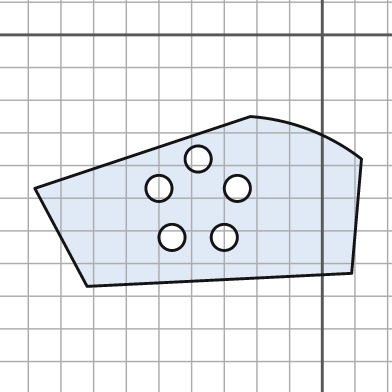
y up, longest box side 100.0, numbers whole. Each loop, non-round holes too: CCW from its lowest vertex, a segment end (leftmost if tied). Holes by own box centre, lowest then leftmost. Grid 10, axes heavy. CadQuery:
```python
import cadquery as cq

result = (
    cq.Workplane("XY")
    .moveTo(-72.0, -77.0)
    .lineTo(9.0, -73.0)
    .lineTo(12.0, -38.0)
    .threePointArc((-4.0, -29.0), (-22.0, -25.0))
    .lineTo(-88.0, -47.0)
    .close()
    .moveTo(-46.0, -62.0)
    .circle(4.0)
    .moveTo(-30.0, -62.0)
    .circle(4.0)
    .moveTo(-50.0, -47.0)
    .circle(4.0)
    .moveTo(-26.0, -47.0)
    .circle(4.0)
    .moveTo(-38.0, -38.0)
    .circle(4.0)
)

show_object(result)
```